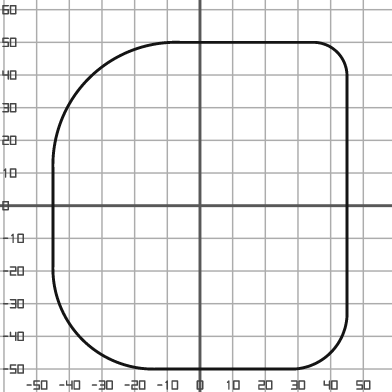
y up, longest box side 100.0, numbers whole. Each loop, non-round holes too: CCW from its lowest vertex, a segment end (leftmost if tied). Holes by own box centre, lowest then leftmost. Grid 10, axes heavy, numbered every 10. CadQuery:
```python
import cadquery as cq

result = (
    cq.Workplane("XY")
    .moveTo(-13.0, -50.0)
    .lineTo(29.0, -50.0)
    .threePointArc((40.0, -45.0), (45.0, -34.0))
    .lineTo(45.0, 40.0)
    .threePointArc((42.0, 47.0), (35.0, 50.0))
    .lineTo(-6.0, 50.0)
    .threePointArc((-34.0, 39.0), (-45.0, 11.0))
    .lineTo(-45.0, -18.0)
    .threePointArc((-36.0, -41.0), (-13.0, -50.0))
    .close()
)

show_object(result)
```